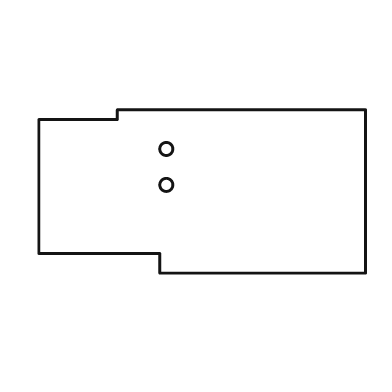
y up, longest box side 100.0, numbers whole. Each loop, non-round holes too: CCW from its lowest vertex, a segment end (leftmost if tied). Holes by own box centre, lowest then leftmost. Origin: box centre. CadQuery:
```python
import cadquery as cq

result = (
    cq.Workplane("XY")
    .moveTo(-13.0, -25.0)
    .lineTo(50.0, -25.0)
    .lineTo(50.0, 25.0)
    .lineTo(-26.0, 25.0)
    .lineTo(-26.0, 22.0)
    .lineTo(-50.0, 22.0)
    .lineTo(-50.0, -19.0)
    .lineTo(-13.0, -19.0)
    .close()
    .moveTo(-11.0, 2.0)
    .circle(2.0)
    .moveTo(-11.0, 13.0)
    .circle(2.0)
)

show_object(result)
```